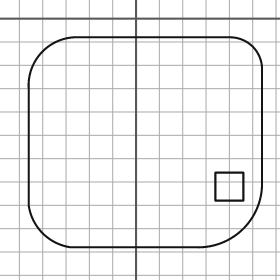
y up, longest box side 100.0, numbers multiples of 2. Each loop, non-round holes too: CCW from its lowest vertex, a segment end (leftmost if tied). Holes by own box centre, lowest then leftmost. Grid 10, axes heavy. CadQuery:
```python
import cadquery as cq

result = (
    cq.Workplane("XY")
    .moveTo(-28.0, -98.0)
    .lineTo(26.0, -98.0)
    .threePointArc((46.0, -90.0), (54.0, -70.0))
    .lineTo(54.0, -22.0)
    .threePointArc((50.0, -12.0), (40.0, -8.0))
    .lineTo(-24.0, -8.0)
    .threePointArc((-40.0, -14.0), (-46.0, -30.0))
    .lineTo(-46.0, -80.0)
    .threePointArc((-40.0, -92.0), (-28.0, -98.0))
    .close()
    .moveTo(34.0, -78.0)
    .lineTo(46.0, -78.0)
    .lineTo(46.0, -66.0)
    .lineTo(34.0, -66.0)
    .close()
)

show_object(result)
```